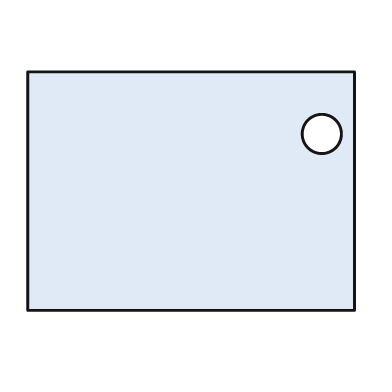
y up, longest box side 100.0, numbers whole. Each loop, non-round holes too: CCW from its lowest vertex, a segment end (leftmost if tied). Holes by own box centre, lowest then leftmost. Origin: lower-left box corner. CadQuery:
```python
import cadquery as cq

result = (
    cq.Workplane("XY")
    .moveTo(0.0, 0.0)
    .lineTo(100.0, 0.0)
    .lineTo(100.0, 73.0)
    .lineTo(0.0, 73.0)
    .close()
    .moveTo(90.0, 54.0)
    .circle(6.0)
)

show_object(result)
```